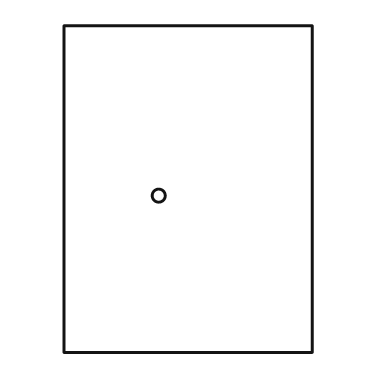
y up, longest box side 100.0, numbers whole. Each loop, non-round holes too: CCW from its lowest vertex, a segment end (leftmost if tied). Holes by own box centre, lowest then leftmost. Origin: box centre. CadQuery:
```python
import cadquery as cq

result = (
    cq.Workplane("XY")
    .moveTo(-38.0, -50.0)
    .lineTo(38.0, -50.0)
    .lineTo(38.0, 50.0)
    .lineTo(-38.0, 50.0)
    .close()
    .moveTo(-9.0, -2.0)
    .circle(2.0)
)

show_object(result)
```